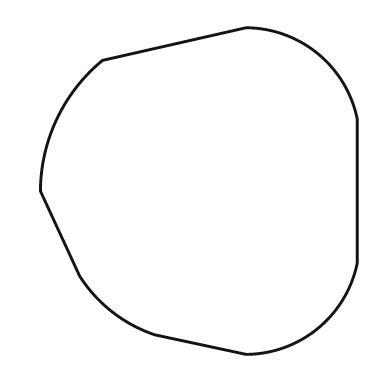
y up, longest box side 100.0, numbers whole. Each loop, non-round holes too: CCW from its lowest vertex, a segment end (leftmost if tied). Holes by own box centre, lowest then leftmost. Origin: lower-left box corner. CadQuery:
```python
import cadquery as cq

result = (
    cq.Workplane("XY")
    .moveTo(63.0, 0.0)
    .threePointArc((85.0, 8.0), (97.0, 28.0))
    .lineTo(97.0, 72.0)
    .threePointArc((85.0, 92.0), (63.0, 100.0))
    .lineTo(19.0, 90.0)
    .threePointArc((5.0, 72.0), (0.0, 50.0))
    .lineTo(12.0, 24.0)
    .threePointArc((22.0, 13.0), (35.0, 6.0))
    .close()
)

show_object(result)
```